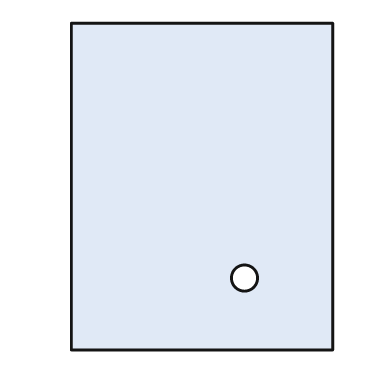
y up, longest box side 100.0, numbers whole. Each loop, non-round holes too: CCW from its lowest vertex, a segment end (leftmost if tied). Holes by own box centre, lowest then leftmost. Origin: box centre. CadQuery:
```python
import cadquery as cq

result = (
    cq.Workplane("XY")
    .moveTo(-40.0, -50.0)
    .lineTo(40.0, -50.0)
    .lineTo(40.0, 50.0)
    .lineTo(-40.0, 50.0)
    .close()
    .moveTo(13.0, -28.0)
    .circle(4.0)
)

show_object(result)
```